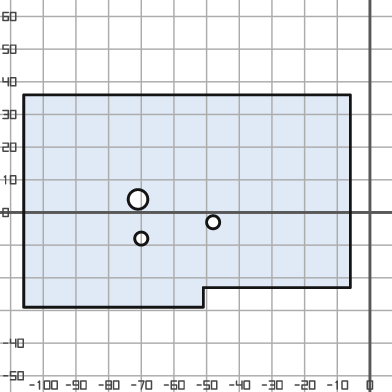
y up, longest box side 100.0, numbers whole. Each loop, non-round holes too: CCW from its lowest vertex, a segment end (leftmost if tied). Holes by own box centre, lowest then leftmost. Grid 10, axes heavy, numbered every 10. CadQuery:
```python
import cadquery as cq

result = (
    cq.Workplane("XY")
    .moveTo(-106.0, -29.0)
    .lineTo(-51.0, -29.0)
    .lineTo(-51.0, -23.0)
    .lineTo(-6.0, -23.0)
    .lineTo(-6.0, 36.0)
    .lineTo(-106.0, 36.0)
    .close()
    .moveTo(-70.0, -8.0)
    .circle(2.0)
    .moveTo(-48.0, -3.0)
    .circle(2.0)
    .moveTo(-71.0, 4.0)
    .circle(3.0)
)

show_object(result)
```